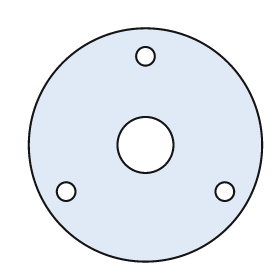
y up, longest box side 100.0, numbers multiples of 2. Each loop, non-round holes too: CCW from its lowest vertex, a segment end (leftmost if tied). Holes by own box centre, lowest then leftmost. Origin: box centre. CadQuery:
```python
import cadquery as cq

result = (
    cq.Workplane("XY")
    .moveTo(0.0, 0.0)
    .circle(50.0)
    .moveTo(-34.0, -20.0)
    .circle(4.0)
    .moveTo(34.0, -20.0)
    .circle(4.0)
    .moveTo(0.0, 0.0)
    .circle(12.0)
    .moveTo(0.0, 38.0)
    .circle(4.0)
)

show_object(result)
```